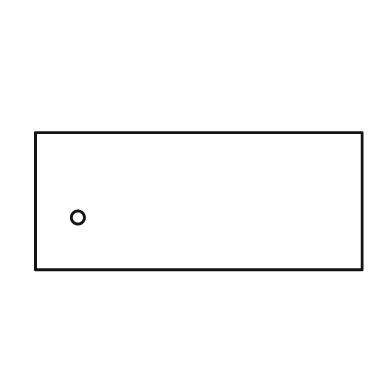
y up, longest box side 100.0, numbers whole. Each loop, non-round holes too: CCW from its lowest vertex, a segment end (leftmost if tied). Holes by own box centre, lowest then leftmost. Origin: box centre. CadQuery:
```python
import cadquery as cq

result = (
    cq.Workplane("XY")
    .moveTo(-50.0, -21.0)
    .lineTo(50.0, -21.0)
    .lineTo(50.0, 21.0)
    .lineTo(-50.0, 21.0)
    .close()
    .moveTo(-37.0, -5.0)
    .circle(2.0)
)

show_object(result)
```